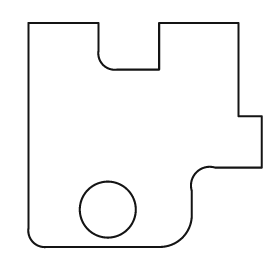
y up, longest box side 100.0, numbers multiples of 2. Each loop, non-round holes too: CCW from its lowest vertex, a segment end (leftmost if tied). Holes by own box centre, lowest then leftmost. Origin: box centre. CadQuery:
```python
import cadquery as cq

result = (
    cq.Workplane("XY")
    .moveTo(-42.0, -48.0)
    .lineTo(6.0, -48.0)
    .threePointArc((16.0, -44.0), (20.0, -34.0))
    .lineTo(20.0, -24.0)
    .threePointArc((22.0, -16.0), (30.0, -14.0))
    .lineTo(50.0, -14.0)
    .lineTo(50.0, 8.0)
    .lineTo(40.0, 8.0)
    .lineTo(40.0, 48.0)
    .lineTo(6.0, 48.0)
    .lineTo(6.0, 28.0)
    .lineTo(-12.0, 28.0)
    .threePointArc((-18.0, 30.0), (-20.0, 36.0))
    .lineTo(-20.0, 48.0)
    .lineTo(-50.0, 48.0)
    .lineTo(-50.0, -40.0)
    .threePointArc((-48.0, -46.0), (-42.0, -48.0))
    .close()
    .moveTo(-16.0, -32.0)
    .circle(12.0)
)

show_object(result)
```